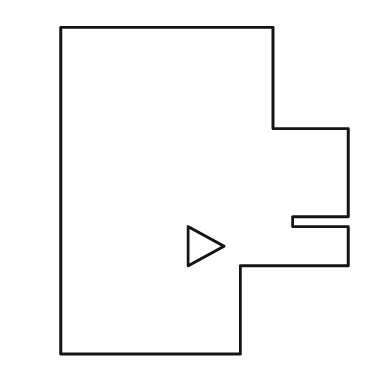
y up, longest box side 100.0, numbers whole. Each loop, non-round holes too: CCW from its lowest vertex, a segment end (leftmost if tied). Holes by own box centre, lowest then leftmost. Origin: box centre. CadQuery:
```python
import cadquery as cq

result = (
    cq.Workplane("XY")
    .moveTo(-44.0, -50.0)
    .lineTo(11.0, -50.0)
    .lineTo(11.0, -23.0)
    .lineTo(44.0, -23.0)
    .lineTo(44.0, -11.0)
    .lineTo(27.0, -11.0)
    .lineTo(27.0, -8.0)
    .lineTo(44.0, -8.0)
    .lineTo(44.0, 19.0)
    .lineTo(21.0, 19.0)
    .lineTo(21.0, 50.0)
    .lineTo(-44.0, 50.0)
    .close()
    .moveTo(-5.0, -23.0)
    .lineTo(6.0, -17.0)
    .lineTo(-5.0, -11.0)
    .close()
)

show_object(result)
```